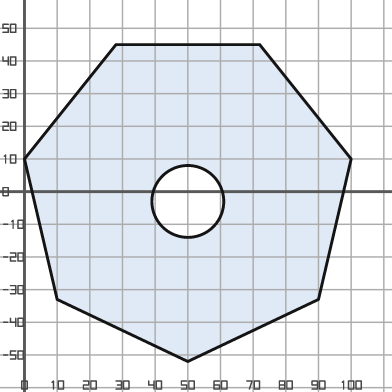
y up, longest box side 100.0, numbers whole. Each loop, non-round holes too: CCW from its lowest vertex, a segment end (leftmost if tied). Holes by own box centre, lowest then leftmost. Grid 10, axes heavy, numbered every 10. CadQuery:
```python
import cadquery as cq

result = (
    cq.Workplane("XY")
    .moveTo(50.0, -52.0)
    .lineTo(90.0, -33.0)
    .lineTo(100.0, 10.0)
    .lineTo(72.0, 45.0)
    .lineTo(28.0, 45.0)
    .lineTo(0.0, 10.0)
    .lineTo(10.0, -33.0)
    .close()
    .moveTo(50.0, -3.0)
    .circle(11.0)
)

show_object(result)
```